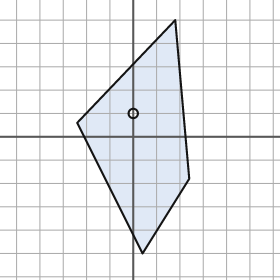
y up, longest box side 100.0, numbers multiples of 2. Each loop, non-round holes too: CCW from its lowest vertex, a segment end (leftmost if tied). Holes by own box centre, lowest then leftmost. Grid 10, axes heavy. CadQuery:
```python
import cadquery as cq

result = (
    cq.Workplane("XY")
    .moveTo(4.0, -50.0)
    .lineTo(24.0, -18.0)
    .lineTo(18.0, 50.0)
    .lineTo(-24.0, 6.0)
    .close()
    .moveTo(0.0, 10.0)
    .circle(2.0)
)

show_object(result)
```